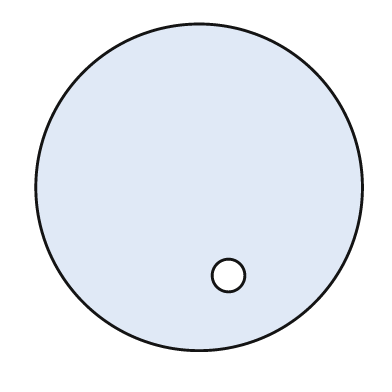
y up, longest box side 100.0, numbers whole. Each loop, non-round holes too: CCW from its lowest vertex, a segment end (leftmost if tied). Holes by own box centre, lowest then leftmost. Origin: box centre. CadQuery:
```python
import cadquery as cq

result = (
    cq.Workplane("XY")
    .moveTo(0.0, 0.0)
    .circle(50.0)
    .moveTo(9.0, -27.0)
    .circle(5.0)
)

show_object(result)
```